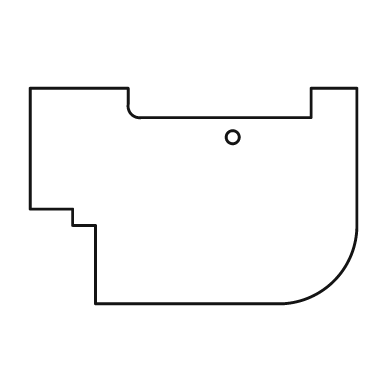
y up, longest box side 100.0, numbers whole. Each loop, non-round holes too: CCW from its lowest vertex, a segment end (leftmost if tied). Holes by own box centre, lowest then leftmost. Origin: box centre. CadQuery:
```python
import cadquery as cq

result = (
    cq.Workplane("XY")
    .moveTo(-30.0, -33.0)
    .lineTo(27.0, -33.0)
    .threePointArc((43.0, -26.0), (50.0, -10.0))
    .lineTo(50.0, 33.0)
    .lineTo(36.0, 33.0)
    .lineTo(36.0, 24.0)
    .lineTo(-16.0, 24.0)
    .threePointArc((-19.0, 25.0), (-20.0, 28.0))
    .lineTo(-20.0, 33.0)
    .lineTo(-50.0, 33.0)
    .lineTo(-50.0, -4.0)
    .lineTo(-37.0, -4.0)
    .lineTo(-37.0, -9.0)
    .lineTo(-30.0, -9.0)
    .close()
    .moveTo(12.0, 18.0)
    .circle(2.0)
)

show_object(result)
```